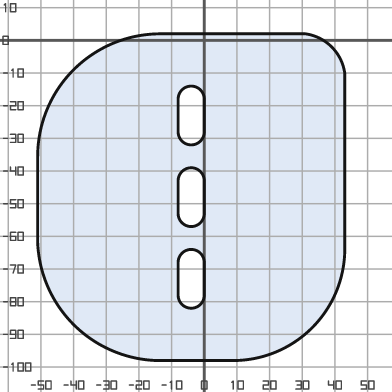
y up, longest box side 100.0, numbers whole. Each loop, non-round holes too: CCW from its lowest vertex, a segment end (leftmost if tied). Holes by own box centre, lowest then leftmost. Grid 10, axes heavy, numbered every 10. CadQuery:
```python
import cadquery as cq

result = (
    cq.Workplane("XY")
    .moveTo(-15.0, -98.0)
    .lineTo(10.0, -98.0)
    .threePointArc((33.0, -88.0), (43.0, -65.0))
    .lineTo(43.0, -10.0)
    .threePointArc((39.0, -2.0), (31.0, 2.0))
    .lineTo(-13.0, 2.0)
    .threePointArc((-40.0, -9.0), (-51.0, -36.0))
    .lineTo(-51.0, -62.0)
    .threePointArc((-40.0, -87.0), (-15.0, -98.0))
    .close()
    .moveTo(-8.0, -78.0)
    .threePointArc((-4.0, -82.0), (0.0, -78.0))
    .lineTo(0.0, -68.0)
    .threePointArc((-4.0, -64.0), (-8.0, -68.0))
    .close()
    .moveTo(-8.0, -53.0)
    .threePointArc((-4.0, -57.0), (0.0, -53.0))
    .lineTo(0.0, -43.0)
    .threePointArc((-4.0, -39.0), (-8.0, -43.0))
    .close()
    .moveTo(-8.0, -28.0)
    .threePointArc((-4.0, -32.0), (0.0, -28.0))
    .lineTo(0.0, -18.0)
    .threePointArc((-4.0, -14.0), (-8.0, -18.0))
    .close()
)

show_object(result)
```